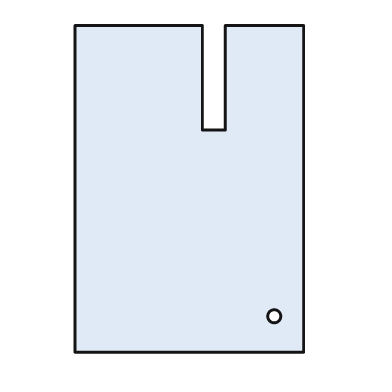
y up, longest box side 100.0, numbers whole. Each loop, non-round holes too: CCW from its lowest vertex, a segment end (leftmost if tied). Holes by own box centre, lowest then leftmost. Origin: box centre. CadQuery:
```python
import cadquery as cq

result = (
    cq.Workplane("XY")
    .moveTo(-35.0, -50.0)
    .lineTo(35.0, -50.0)
    .lineTo(35.0, 50.0)
    .lineTo(11.0, 50.0)
    .lineTo(11.0, 18.0)
    .lineTo(4.0, 18.0)
    .lineTo(4.0, 50.0)
    .lineTo(-35.0, 50.0)
    .close()
    .moveTo(26.0, -39.0)
    .circle(2.0)
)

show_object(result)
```